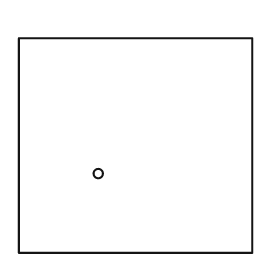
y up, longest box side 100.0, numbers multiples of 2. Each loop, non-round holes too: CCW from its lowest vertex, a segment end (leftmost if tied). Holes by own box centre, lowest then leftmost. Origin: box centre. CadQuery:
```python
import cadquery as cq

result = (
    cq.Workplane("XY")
    .moveTo(-50.0, -46.0)
    .lineTo(50.0, -46.0)
    .lineTo(50.0, 46.0)
    .lineTo(-50.0, 46.0)
    .close()
    .moveTo(-16.0, -12.0)
    .circle(2.0)
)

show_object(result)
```